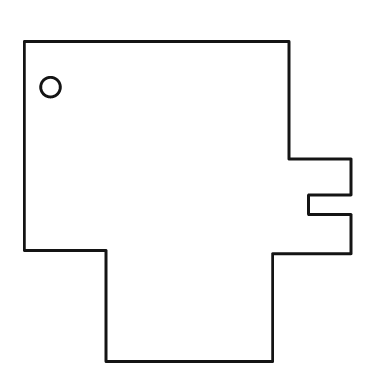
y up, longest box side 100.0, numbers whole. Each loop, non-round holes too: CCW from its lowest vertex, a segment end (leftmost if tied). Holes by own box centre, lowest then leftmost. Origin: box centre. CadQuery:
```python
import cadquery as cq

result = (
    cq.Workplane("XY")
    .moveTo(-25.0, -49.0)
    .lineTo(26.0, -49.0)
    .lineTo(26.0, -16.0)
    .lineTo(50.0, -16.0)
    .lineTo(50.0, -4.0)
    .lineTo(37.0, -4.0)
    .lineTo(37.0, 2.0)
    .lineTo(50.0, 2.0)
    .lineTo(50.0, 13.0)
    .lineTo(31.0, 13.0)
    .lineTo(31.0, 49.0)
    .lineTo(-50.0, 49.0)
    .lineTo(-50.0, -15.0)
    .lineTo(-25.0, -15.0)
    .close()
    .moveTo(-42.0, 35.0)
    .circle(3.0)
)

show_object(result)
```